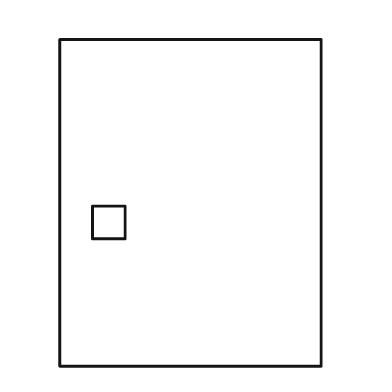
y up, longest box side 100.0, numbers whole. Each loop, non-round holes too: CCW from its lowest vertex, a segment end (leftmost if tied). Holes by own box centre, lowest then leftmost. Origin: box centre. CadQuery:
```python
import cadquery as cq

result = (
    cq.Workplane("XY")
    .moveTo(-40.0, -50.0)
    .lineTo(40.0, -50.0)
    .lineTo(40.0, 50.0)
    .lineTo(-40.0, 50.0)
    .close()
    .moveTo(-30.0, -11.0)
    .lineTo(-20.0, -11.0)
    .lineTo(-20.0, -1.0)
    .lineTo(-30.0, -1.0)
    .close()
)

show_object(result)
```